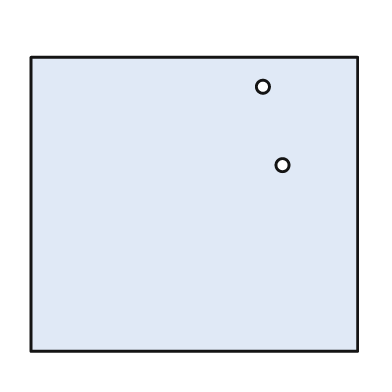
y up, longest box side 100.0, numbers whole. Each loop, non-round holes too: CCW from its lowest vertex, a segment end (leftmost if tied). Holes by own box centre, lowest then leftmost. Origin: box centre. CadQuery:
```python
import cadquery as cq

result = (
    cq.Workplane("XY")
    .moveTo(-50.0, -45.0)
    .lineTo(50.0, -45.0)
    .lineTo(50.0, 45.0)
    .lineTo(-50.0, 45.0)
    .close()
    .moveTo(27.0, 12.0)
    .circle(2.0)
    .moveTo(21.0, 36.0)
    .circle(2.0)
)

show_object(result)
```